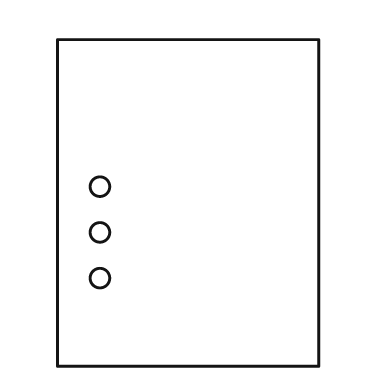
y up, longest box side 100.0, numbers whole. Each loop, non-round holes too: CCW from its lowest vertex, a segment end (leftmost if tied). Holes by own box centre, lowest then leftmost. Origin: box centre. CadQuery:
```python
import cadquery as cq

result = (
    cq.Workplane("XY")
    .moveTo(-40.0, -50.0)
    .lineTo(40.0, -50.0)
    .lineTo(40.0, 50.0)
    .lineTo(-40.0, 50.0)
    .close()
    .moveTo(-27.0, -23.0)
    .circle(3.0)
    .moveTo(-27.0, -9.0)
    .circle(3.0)
    .moveTo(-27.0, 5.0)
    .circle(3.0)
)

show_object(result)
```